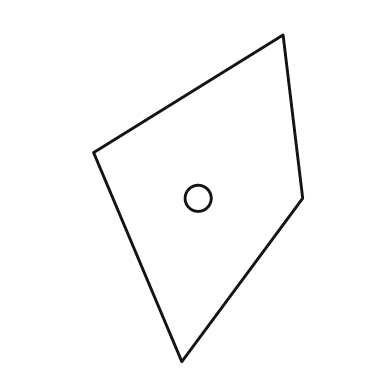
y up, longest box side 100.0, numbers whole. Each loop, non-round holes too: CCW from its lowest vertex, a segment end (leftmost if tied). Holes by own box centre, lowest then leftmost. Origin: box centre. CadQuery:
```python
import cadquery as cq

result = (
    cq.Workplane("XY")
    .moveTo(-5.0, -50.0)
    .lineTo(32.0, 0.0)
    .lineTo(26.0, 50.0)
    .lineTo(-32.0, 14.0)
    .close()
    .moveTo(0.0, 0.0)
    .circle(4.0)
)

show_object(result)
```